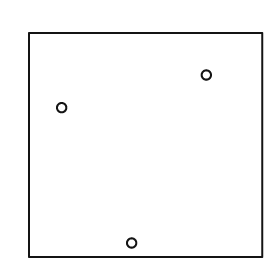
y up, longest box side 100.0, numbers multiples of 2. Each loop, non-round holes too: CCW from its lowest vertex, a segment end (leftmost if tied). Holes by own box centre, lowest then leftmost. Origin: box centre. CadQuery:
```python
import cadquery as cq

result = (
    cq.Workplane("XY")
    .moveTo(-50.0, -48.0)
    .lineTo(50.0, -48.0)
    .lineTo(50.0, 48.0)
    .lineTo(-50.0, 48.0)
    .close()
    .moveTo(-6.0, -42.0)
    .circle(2.0)
    .moveTo(-36.0, 16.0)
    .circle(2.0)
    .moveTo(26.0, 30.0)
    .circle(2.0)
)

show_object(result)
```